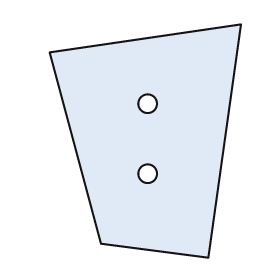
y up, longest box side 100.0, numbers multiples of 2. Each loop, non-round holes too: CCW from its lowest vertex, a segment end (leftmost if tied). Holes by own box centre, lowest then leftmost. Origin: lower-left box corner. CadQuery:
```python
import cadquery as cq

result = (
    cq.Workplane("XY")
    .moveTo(68.0, 0.0)
    .lineTo(82.0, 100.0)
    .lineTo(0.0, 88.0)
    .lineTo(22.0, 6.0)
    .close()
    .moveTo(42.0, 36.0)
    .circle(4.0)
    .moveTo(42.0, 66.0)
    .circle(4.0)
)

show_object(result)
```